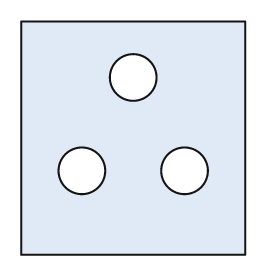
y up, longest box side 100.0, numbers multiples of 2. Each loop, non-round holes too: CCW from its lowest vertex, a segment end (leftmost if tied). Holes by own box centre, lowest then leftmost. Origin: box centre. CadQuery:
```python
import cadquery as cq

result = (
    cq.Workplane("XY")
    .moveTo(-48.0, -50.0)
    .lineTo(48.0, -50.0)
    .lineTo(48.0, 50.0)
    .lineTo(-48.0, 50.0)
    .close()
    .moveTo(-22.0, -14.0)
    .circle(10.0)
    .moveTo(22.0, -14.0)
    .circle(10.0)
    .moveTo(0.0, 26.0)
    .circle(10.0)
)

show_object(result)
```